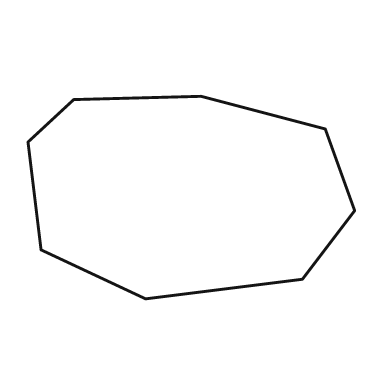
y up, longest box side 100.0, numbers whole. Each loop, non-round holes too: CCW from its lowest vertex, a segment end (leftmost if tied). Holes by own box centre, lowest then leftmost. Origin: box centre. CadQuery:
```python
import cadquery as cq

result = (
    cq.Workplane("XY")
    .moveTo(-14.0, -31.0)
    .lineTo(34.0, -25.0)
    .lineTo(50.0, -4.0)
    .lineTo(41.0, 21.0)
    .lineTo(3.0, 31.0)
    .lineTo(-36.0, 30.0)
    .lineTo(-50.0, 17.0)
    .lineTo(-46.0, -16.0)
    .close()
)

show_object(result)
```